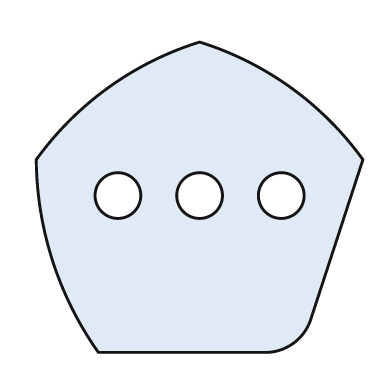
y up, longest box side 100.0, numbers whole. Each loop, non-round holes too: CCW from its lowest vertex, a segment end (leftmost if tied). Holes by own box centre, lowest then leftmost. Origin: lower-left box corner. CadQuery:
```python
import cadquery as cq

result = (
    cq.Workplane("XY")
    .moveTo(19.0, 0.0)
    .lineTo(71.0, 0.0)
    .threePointArc((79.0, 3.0), (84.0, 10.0))
    .lineTo(100.0, 59.0)
    .threePointArc((78.0, 81.0), (50.0, 95.0))
    .threePointArc((22.0, 81.0), (0.0, 59.0))
    .threePointArc((5.0, 28.0), (19.0, 0.0))
    .close()
    .moveTo(25.0, 48.0)
    .circle(7.0)
    .moveTo(50.0, 48.0)
    .circle(7.0)
    .moveTo(75.0, 48.0)
    .circle(7.0)
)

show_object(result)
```